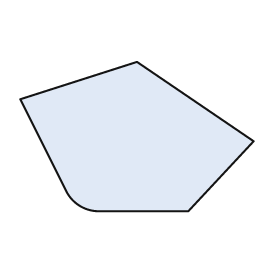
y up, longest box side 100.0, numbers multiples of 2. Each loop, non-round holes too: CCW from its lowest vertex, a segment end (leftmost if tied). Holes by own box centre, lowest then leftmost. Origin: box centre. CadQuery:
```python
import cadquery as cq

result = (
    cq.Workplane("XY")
    .moveTo(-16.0, -32.0)
    .lineTo(22.0, -32.0)
    .lineTo(50.0, -2.0)
    .lineTo(0.0, 32.0)
    .lineTo(-50.0, 16.0)
    .lineTo(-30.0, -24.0)
    .threePointArc((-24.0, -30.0), (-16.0, -32.0))
    .close()
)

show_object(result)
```